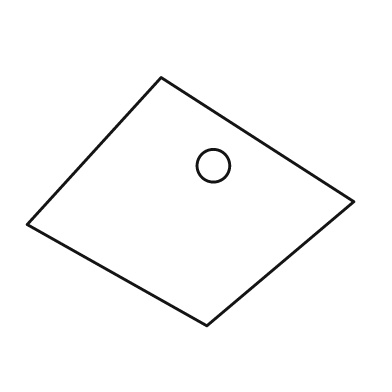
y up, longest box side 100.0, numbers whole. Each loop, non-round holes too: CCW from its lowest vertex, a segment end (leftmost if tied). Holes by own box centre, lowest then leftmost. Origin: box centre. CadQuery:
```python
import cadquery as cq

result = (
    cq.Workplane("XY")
    .moveTo(5.0, -38.0)
    .lineTo(50.0, 0.0)
    .lineTo(-9.0, 38.0)
    .lineTo(-50.0, -7.0)
    .close()
    .moveTo(7.0, 11.0)
    .circle(5.0)
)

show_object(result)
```